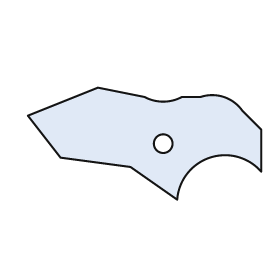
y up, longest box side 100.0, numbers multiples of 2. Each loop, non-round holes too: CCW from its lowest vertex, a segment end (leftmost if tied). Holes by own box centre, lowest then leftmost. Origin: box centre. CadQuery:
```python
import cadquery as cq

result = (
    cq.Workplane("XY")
    .moveTo(14.0, -24.0)
    .threePointArc((28.0, -6.0), (50.0, -12.0))
    .lineTo(50.0, 6.0)
    .lineTo(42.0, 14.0)
    .threePointArc((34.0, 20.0), (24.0, 20.0))
    .lineTo(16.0, 20.0)
    .threePointArc((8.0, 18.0), (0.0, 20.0))
    .lineTo(-20.0, 24.0)
    .lineTo(-50.0, 12.0)
    .lineTo(-36.0, -6.0)
    .lineTo(-6.0, -10.0)
    .close()
    .moveTo(8.0, 0.0)
    .circle(4.0)
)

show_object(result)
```